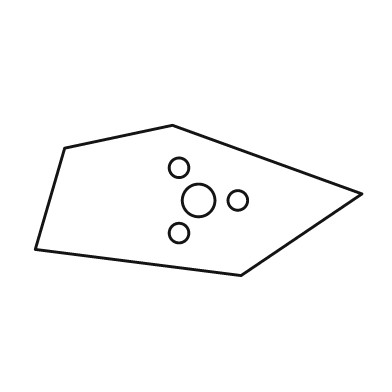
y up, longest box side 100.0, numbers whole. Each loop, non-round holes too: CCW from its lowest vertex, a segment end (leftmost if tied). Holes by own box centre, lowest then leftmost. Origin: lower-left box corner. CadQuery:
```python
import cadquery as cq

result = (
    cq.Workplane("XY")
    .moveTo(63.0, 0.0)
    .lineTo(100.0, 25.0)
    .lineTo(42.0, 46.0)
    .lineTo(9.0, 39.0)
    .lineTo(0.0, 8.0)
    .close()
    .moveTo(44.0, 13.0)
    .circle(3.0)
    .moveTo(50.0, 23.0)
    .circle(5.0)
    .moveTo(62.0, 23.0)
    .circle(3.0)
    .moveTo(44.0, 33.0)
    .circle(3.0)
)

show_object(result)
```